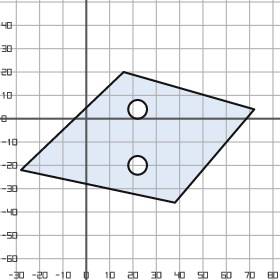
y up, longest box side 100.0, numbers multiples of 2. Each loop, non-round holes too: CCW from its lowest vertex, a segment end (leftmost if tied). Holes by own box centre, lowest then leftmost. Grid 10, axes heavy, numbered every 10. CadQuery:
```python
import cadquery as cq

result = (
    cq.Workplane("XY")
    .moveTo(38.0, -36.0)
    .lineTo(72.0, 4.0)
    .lineTo(16.0, 20.0)
    .lineTo(-28.0, -22.0)
    .close()
    .moveTo(22.0, -20.0)
    .circle(4.0)
    .moveTo(22.0, 4.0)
    .circle(4.0)
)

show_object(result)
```